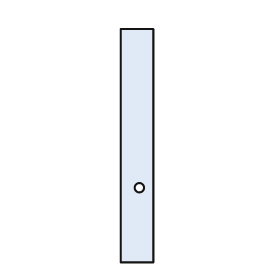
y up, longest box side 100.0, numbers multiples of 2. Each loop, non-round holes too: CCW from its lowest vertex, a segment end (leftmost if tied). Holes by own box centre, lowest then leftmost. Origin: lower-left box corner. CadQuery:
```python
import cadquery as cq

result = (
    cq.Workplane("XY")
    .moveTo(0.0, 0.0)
    .lineTo(14.0, 0.0)
    .lineTo(14.0, 100.0)
    .lineTo(0.0, 100.0)
    .close()
    .moveTo(8.0, 32.0)
    .circle(2.0)
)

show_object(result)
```